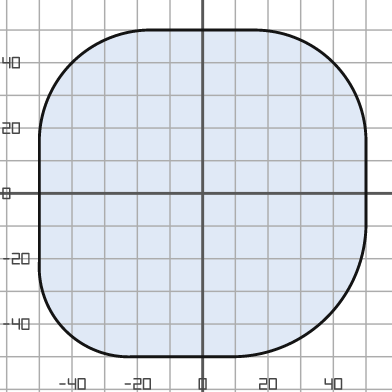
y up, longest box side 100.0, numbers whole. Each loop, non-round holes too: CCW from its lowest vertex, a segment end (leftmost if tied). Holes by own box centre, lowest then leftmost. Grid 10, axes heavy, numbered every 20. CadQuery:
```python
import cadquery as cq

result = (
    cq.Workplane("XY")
    .moveTo(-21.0, -50.0)
    .lineTo(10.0, -50.0)
    .threePointArc((38.0, -38.0), (50.0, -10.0))
    .lineTo(50.0, 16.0)
    .threePointArc((40.0, 40.0), (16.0, 50.0))
    .lineTo(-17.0, 50.0)
    .threePointArc((-40.0, 40.0), (-50.0, 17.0))
    .lineTo(-50.0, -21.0)
    .threePointArc((-42.0, -42.0), (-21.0, -50.0))
    .close()
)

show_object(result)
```